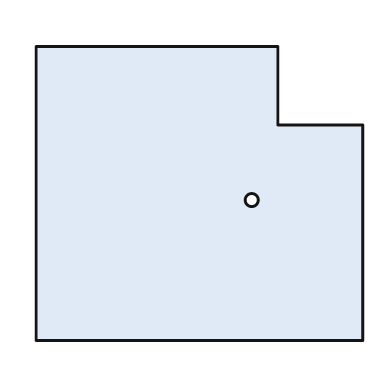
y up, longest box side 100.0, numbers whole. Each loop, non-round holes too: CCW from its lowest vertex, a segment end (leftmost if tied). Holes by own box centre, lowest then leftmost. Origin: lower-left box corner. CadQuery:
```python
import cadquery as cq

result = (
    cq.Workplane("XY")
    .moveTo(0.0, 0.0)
    .lineTo(100.0, 0.0)
    .lineTo(100.0, 66.0)
    .lineTo(74.0, 66.0)
    .lineTo(74.0, 90.0)
    .lineTo(0.0, 90.0)
    .close()
    .moveTo(66.0, 43.0)
    .circle(2.0)
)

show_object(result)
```